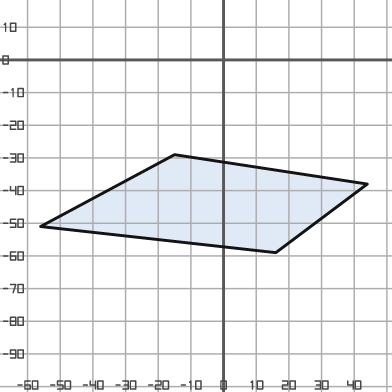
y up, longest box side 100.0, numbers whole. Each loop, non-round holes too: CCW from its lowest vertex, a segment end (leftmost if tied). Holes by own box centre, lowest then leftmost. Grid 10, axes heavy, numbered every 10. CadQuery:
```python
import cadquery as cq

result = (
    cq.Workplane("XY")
    .moveTo(16.0, -59.0)
    .lineTo(44.0, -38.0)
    .lineTo(-15.0, -29.0)
    .lineTo(-56.0, -51.0)
    .close()
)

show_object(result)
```